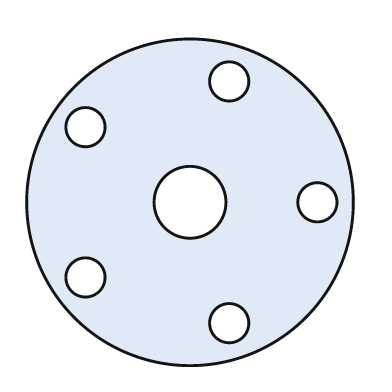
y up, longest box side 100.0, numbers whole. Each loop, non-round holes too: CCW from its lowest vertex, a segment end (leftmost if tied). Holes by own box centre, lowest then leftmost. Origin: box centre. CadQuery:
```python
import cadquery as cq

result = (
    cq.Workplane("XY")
    .moveTo(0.0, 0.0)
    .circle(50.0)
    .moveTo(12.0, -37.0)
    .circle(6.0)
    .moveTo(-32.0, -23.0)
    .circle(6.0)
    .moveTo(0.0, 0.0)
    .circle(11.0)
    .moveTo(39.0, 0.0)
    .circle(6.0)
    .moveTo(-32.0, 23.0)
    .circle(6.0)
    .moveTo(12.0, 37.0)
    .circle(6.0)
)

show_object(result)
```